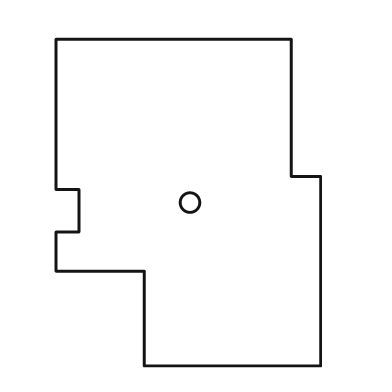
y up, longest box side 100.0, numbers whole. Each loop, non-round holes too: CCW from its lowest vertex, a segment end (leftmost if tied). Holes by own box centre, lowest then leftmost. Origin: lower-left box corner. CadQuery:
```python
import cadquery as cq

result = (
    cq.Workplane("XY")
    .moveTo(27.0, 0.0)
    .lineTo(81.0, 0.0)
    .lineTo(81.0, 58.0)
    .lineTo(72.0, 58.0)
    .lineTo(72.0, 100.0)
    .lineTo(0.0, 100.0)
    .lineTo(0.0, 54.0)
    .lineTo(7.0, 54.0)
    .lineTo(7.0, 41.0)
    .lineTo(0.0, 41.0)
    .lineTo(0.0, 29.0)
    .lineTo(27.0, 29.0)
    .close()
    .moveTo(41.0, 50.0)
    .circle(3.0)
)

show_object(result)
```